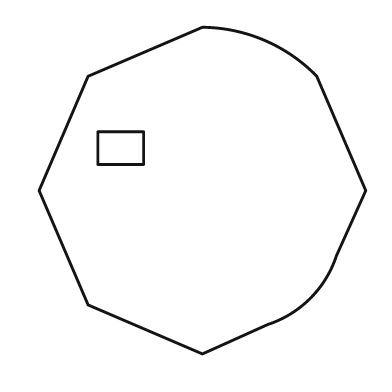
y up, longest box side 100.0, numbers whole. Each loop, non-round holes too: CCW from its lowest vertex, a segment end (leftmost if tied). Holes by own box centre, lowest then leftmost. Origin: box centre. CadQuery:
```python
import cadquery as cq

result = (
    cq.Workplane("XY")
    .moveTo(0.0, -50.0)
    .lineTo(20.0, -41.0)
    .threePointArc((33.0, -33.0), (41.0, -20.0))
    .lineTo(50.0, 0.0)
    .lineTo(35.0, 35.0)
    .threePointArc((19.0, 46.0), (0.0, 50.0))
    .lineTo(-35.0, 35.0)
    .lineTo(-50.0, 0.0)
    .lineTo(-35.0, -35.0)
    .close()
    .moveTo(-32.0, 8.0)
    .lineTo(-18.0, 8.0)
    .lineTo(-18.0, 18.0)
    .lineTo(-32.0, 18.0)
    .close()
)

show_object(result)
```